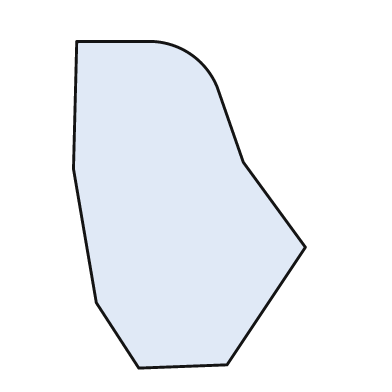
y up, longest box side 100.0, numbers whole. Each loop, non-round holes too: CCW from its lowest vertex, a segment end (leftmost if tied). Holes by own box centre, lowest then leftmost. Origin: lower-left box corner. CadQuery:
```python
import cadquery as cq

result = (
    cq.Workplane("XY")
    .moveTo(20.0, 0.0)
    .lineTo(47.0, 1.0)
    .lineTo(71.0, 37.0)
    .lineTo(52.0, 63.0)
    .lineTo(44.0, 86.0)
    .threePointArc((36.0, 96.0), (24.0, 100.0))
    .lineTo(1.0, 100.0)
    .lineTo(0.0, 61.0)
    .lineTo(7.0, 20.0)
    .close()
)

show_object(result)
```